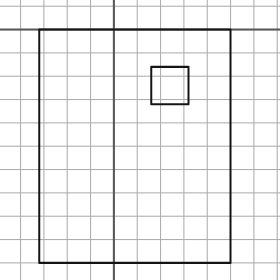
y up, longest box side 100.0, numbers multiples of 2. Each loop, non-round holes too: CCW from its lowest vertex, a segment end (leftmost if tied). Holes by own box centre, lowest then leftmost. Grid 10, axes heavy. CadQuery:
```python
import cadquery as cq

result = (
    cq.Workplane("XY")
    .moveTo(-32.0, -100.0)
    .lineTo(50.0, -100.0)
    .lineTo(50.0, 0.0)
    .lineTo(-32.0, 0.0)
    .close()
    .moveTo(16.0, -32.0)
    .lineTo(32.0, -32.0)
    .lineTo(32.0, -16.0)
    .lineTo(16.0, -16.0)
    .close()
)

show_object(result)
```